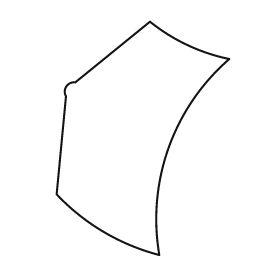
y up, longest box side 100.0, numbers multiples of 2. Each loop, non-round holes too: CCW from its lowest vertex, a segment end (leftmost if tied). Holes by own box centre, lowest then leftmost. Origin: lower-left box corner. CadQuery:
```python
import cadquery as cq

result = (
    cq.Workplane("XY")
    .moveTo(44.0, 0.0)
    .threePointArc((48.0, 46.0), (74.0, 84.0))
    .threePointArc((56.0, 90.0), (40.0, 100.0))
    .lineTo(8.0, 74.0)
    .threePointArc((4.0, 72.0), (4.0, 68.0))
    .lineTo(0.0, 26.0)
    .threePointArc((20.0, 10.0), (44.0, 0.0))
    .close()
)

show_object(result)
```